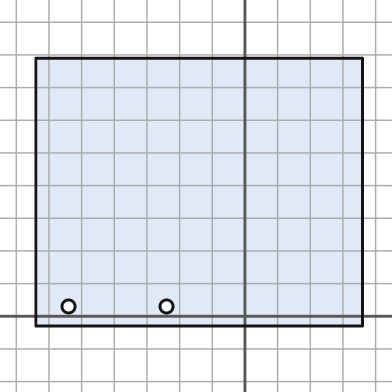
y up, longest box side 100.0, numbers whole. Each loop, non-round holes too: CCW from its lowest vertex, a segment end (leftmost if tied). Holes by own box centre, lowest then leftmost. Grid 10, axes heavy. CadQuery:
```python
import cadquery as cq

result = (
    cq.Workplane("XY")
    .moveTo(-64.0, -3.0)
    .lineTo(36.0, -3.0)
    .lineTo(36.0, 79.0)
    .lineTo(-64.0, 79.0)
    .close()
    .moveTo(-54.0, 3.0)
    .circle(2.0)
    .moveTo(-24.0, 3.0)
    .circle(2.0)
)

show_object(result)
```